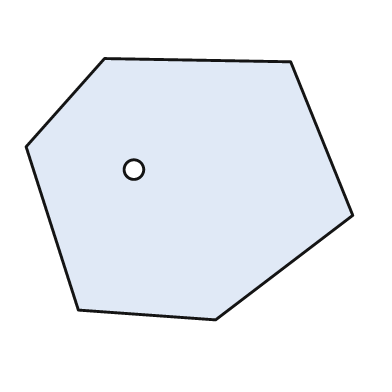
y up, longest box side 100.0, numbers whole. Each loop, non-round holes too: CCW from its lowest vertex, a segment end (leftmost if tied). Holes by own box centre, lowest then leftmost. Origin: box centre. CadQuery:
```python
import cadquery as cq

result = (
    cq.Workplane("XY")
    .moveTo(8.0, -40.0)
    .lineTo(50.0, -8.0)
    .lineTo(31.0, 39.0)
    .lineTo(-26.0, 40.0)
    .lineTo(-50.0, 13.0)
    .lineTo(-34.0, -37.0)
    .close()
    .moveTo(-17.0, 6.0)
    .circle(3.0)
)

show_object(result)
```